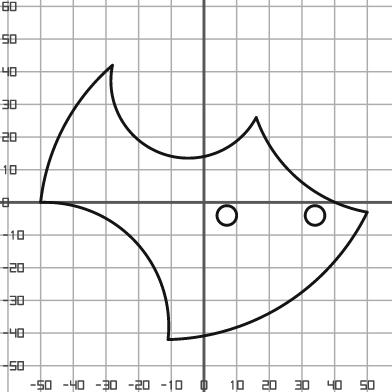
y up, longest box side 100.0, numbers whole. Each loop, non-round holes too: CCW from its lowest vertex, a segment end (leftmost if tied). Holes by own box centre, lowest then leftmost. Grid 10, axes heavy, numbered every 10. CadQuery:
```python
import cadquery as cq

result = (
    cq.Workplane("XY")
    .moveTo(-11.0, -42.0)
    .threePointArc((25.0, -31.0), (50.0, -3.0))
    .threePointArc((29.0, 7.0), (16.0, 26.0))
    .threePointArc((-13.0, 15.0), (-28.0, 42.0))
    .threePointArc((-43.0, 23.0), (-50.0, 0.0))
    .threePointArc((-21.0, -12.0), (-11.0, -42.0))
    .close()
    .moveTo(7.0, -4.0)
    .circle(3.0)
    .moveTo(34.0, -4.0)
    .circle(3.0)
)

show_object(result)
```